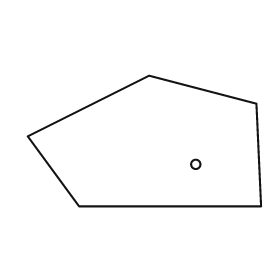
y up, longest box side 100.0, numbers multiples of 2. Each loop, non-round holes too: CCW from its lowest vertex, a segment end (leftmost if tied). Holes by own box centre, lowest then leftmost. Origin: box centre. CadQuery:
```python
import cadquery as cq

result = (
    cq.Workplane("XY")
    .moveTo(-28.0, -28.0)
    .lineTo(50.0, -28.0)
    .lineTo(48.0, 16.0)
    .lineTo(2.0, 28.0)
    .lineTo(-50.0, 2.0)
    .close()
    .moveTo(22.0, -10.0)
    .circle(2.0)
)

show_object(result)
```